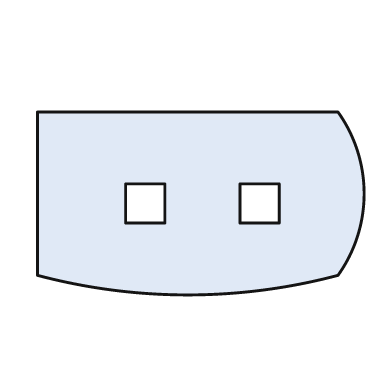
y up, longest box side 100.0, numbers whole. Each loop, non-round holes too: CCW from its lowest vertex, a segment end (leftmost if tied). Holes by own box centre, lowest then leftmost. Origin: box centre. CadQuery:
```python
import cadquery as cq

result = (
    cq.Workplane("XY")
    .moveTo(-50.0, -22.0)
    .threePointArc((-4.0, -28.0), (42.0, -22.0))
    .threePointArc((50.0, 3.0), (42.0, 28.0))
    .lineTo(-50.0, 28.0)
    .close()
    .moveTo(-23.0, -6.0)
    .lineTo(-11.0, -6.0)
    .lineTo(-11.0, 6.0)
    .lineTo(-23.0, 6.0)
    .close()
    .moveTo(12.0, -6.0)
    .lineTo(24.0, -6.0)
    .lineTo(24.0, 6.0)
    .lineTo(12.0, 6.0)
    .close()
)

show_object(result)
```